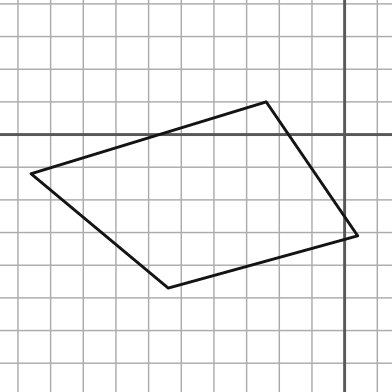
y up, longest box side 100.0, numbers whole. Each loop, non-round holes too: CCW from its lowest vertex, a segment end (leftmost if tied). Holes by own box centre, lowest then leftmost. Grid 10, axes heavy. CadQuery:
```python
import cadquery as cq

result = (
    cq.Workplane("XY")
    .moveTo(-54.0, -47.0)
    .lineTo(4.0, -31.0)
    .lineTo(-24.0, 10.0)
    .lineTo(-96.0, -12.0)
    .close()
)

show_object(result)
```